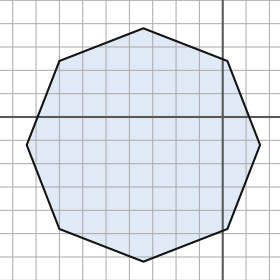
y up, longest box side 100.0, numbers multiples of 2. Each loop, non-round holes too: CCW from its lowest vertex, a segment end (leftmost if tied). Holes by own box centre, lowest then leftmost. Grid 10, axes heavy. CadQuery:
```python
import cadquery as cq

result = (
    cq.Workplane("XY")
    .moveTo(-34.0, -62.0)
    .lineTo(2.0, -48.0)
    .lineTo(16.0, -12.0)
    .lineTo(2.0, 24.0)
    .lineTo(-34.0, 38.0)
    .lineTo(-70.0, 24.0)
    .lineTo(-84.0, -12.0)
    .lineTo(-70.0, -48.0)
    .close()
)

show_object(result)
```